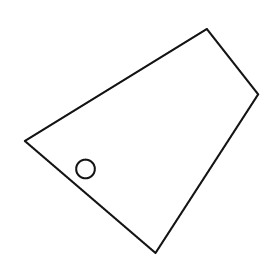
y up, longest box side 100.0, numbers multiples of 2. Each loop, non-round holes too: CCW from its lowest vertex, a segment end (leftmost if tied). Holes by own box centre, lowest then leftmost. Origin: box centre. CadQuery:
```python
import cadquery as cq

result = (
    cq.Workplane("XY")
    .moveTo(6.0, -48.0)
    .lineTo(50.0, 20.0)
    .lineTo(28.0, 48.0)
    .lineTo(-50.0, 0.0)
    .close()
    .moveTo(-24.0, -12.0)
    .circle(4.0)
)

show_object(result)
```